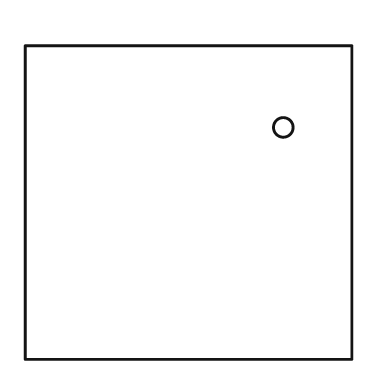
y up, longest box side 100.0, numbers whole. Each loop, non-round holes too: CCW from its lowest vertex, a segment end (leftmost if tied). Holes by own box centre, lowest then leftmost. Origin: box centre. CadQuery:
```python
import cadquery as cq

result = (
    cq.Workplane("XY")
    .moveTo(-50.0, -48.0)
    .lineTo(50.0, -48.0)
    .lineTo(50.0, 48.0)
    .lineTo(-50.0, 48.0)
    .close()
    .moveTo(29.0, 23.0)
    .circle(3.0)
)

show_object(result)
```